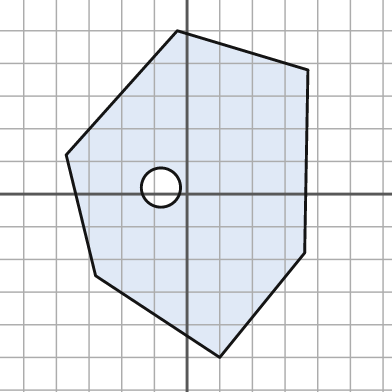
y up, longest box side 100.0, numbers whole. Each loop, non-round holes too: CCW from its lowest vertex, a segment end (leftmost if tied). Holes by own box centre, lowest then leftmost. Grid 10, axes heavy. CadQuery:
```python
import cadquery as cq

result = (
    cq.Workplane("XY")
    .moveTo(10.0, -50.0)
    .lineTo(36.0, -18.0)
    .lineTo(37.0, 38.0)
    .lineTo(-3.0, 50.0)
    .lineTo(-37.0, 12.0)
    .lineTo(-28.0, -25.0)
    .close()
    .moveTo(-8.0, 2.0)
    .circle(6.0)
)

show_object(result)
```